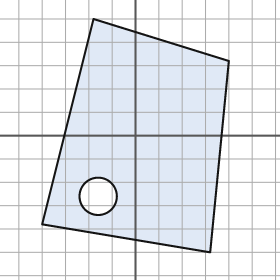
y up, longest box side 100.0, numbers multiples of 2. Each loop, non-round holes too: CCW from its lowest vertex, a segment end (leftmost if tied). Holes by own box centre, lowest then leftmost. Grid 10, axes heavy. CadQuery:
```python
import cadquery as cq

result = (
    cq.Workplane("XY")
    .moveTo(32.0, -50.0)
    .lineTo(40.0, 32.0)
    .lineTo(-18.0, 50.0)
    .lineTo(-40.0, -38.0)
    .close()
    .moveTo(-16.0, -26.0)
    .circle(8.0)
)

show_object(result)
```